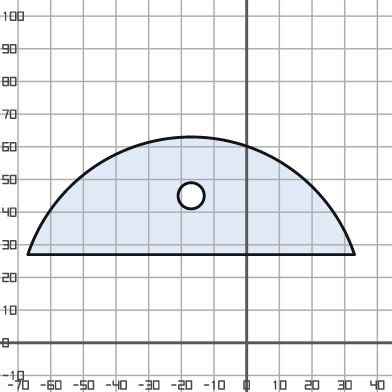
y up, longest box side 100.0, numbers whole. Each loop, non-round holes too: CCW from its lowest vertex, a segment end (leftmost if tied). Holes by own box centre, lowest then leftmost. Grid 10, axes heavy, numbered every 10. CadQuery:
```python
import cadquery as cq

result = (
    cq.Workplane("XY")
    .moveTo(-67.0, 27.0)
    .lineTo(33.0, 27.0)
    .threePointArc((-17.0, 63.0), (-67.0, 27.0))
    .close()
    .moveTo(-17.0, 45.0)
    .circle(4.0)
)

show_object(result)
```